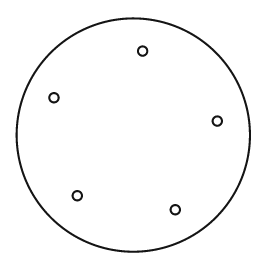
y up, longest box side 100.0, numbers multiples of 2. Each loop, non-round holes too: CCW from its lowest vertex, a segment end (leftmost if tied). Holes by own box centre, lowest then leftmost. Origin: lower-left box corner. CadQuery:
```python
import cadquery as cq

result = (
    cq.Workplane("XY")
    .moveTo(50.0, 50.0)
    .circle(50.0)
    .moveTo(68.0, 18.0)
    .circle(2.0)
    .moveTo(26.0, 24.0)
    .circle(2.0)
    .moveTo(86.0, 56.0)
    .circle(2.0)
    .moveTo(16.0, 66.0)
    .circle(2.0)
    .moveTo(54.0, 86.0)
    .circle(2.0)
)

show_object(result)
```